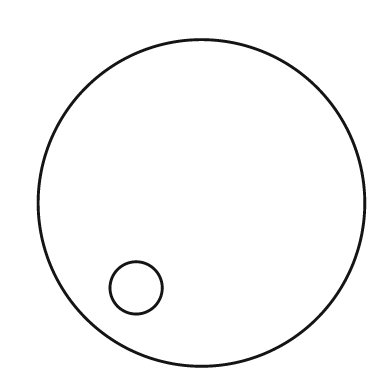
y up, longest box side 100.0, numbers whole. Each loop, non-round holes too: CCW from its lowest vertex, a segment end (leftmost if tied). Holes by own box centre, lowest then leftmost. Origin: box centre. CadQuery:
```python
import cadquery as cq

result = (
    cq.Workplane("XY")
    .moveTo(0.0, 0.0)
    .circle(50.0)
    .moveTo(-20.0, -26.0)
    .circle(8.0)
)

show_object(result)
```